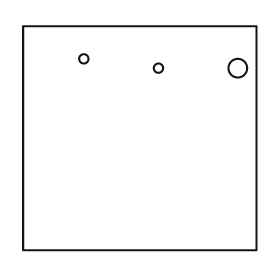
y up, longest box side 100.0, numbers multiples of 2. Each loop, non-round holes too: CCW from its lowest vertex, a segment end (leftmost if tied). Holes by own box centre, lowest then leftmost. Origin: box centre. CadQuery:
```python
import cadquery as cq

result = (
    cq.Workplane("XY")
    .moveTo(-50.0, -48.0)
    .lineTo(50.0, -48.0)
    .lineTo(50.0, 48.0)
    .lineTo(-50.0, 48.0)
    .close()
    .moveTo(8.0, 30.0)
    .circle(2.0)
    .moveTo(42.0, 30.0)
    .circle(4.0)
    .moveTo(-24.0, 34.0)
    .circle(2.0)
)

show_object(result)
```